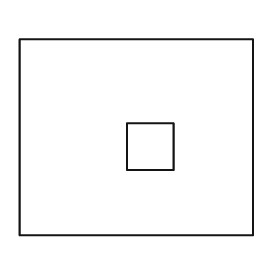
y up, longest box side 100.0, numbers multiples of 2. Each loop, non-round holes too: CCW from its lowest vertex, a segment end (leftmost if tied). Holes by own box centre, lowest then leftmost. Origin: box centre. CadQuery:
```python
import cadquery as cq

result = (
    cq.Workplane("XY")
    .moveTo(-50.0, -42.0)
    .lineTo(50.0, -42.0)
    .lineTo(50.0, 42.0)
    .lineTo(-50.0, 42.0)
    .close()
    .moveTo(-4.0, -14.0)
    .lineTo(16.0, -14.0)
    .lineTo(16.0, 6.0)
    .lineTo(-4.0, 6.0)
    .close()
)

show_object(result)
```